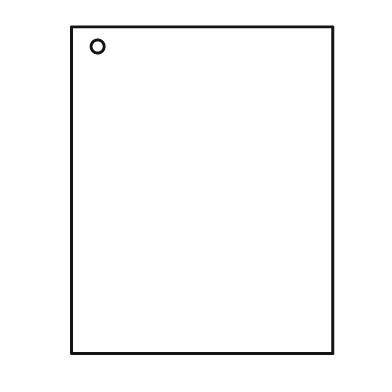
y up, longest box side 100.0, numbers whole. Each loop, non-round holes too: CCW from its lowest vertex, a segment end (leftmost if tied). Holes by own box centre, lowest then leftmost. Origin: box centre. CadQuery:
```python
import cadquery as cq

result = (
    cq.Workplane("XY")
    .moveTo(-40.0, -50.0)
    .lineTo(40.0, -50.0)
    .lineTo(40.0, 50.0)
    .lineTo(-40.0, 50.0)
    .close()
    .moveTo(-32.0, 44.0)
    .circle(2.0)
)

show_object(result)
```